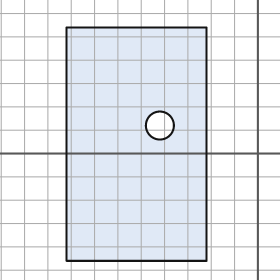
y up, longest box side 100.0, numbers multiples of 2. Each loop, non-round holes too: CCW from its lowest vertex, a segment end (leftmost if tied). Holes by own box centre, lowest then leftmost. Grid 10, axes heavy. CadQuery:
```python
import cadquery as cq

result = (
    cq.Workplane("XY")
    .moveTo(-82.0, -46.0)
    .lineTo(-22.0, -46.0)
    .lineTo(-22.0, 54.0)
    .lineTo(-82.0, 54.0)
    .close()
    .moveTo(-42.0, 12.0)
    .circle(6.0)
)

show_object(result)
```